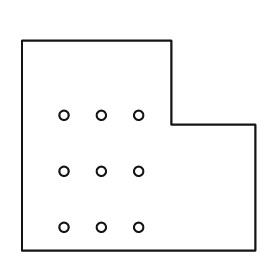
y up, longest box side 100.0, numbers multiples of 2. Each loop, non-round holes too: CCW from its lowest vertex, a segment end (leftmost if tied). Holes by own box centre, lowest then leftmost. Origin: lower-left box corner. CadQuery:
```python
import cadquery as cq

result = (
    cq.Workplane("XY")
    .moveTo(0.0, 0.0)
    .lineTo(100.0, 0.0)
    .lineTo(100.0, 54.0)
    .lineTo(64.0, 54.0)
    .lineTo(64.0, 90.0)
    .lineTo(0.0, 90.0)
    .close()
    .moveTo(18.0, 10.0)
    .circle(2.0)
    .moveTo(34.0, 10.0)
    .circle(2.0)
    .moveTo(50.0, 10.0)
    .circle(2.0)
    .moveTo(18.0, 34.0)
    .circle(2.0)
    .moveTo(34.0, 34.0)
    .circle(2.0)
    .moveTo(50.0, 34.0)
    .circle(2.0)
    .moveTo(18.0, 58.0)
    .circle(2.0)
    .moveTo(34.0, 58.0)
    .circle(2.0)
    .moveTo(50.0, 58.0)
    .circle(2.0)
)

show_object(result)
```